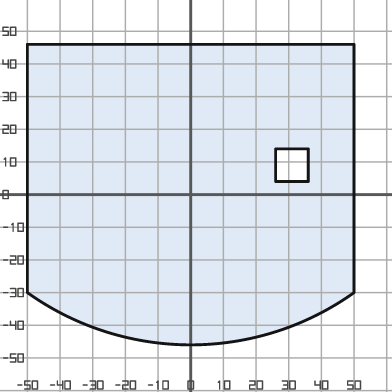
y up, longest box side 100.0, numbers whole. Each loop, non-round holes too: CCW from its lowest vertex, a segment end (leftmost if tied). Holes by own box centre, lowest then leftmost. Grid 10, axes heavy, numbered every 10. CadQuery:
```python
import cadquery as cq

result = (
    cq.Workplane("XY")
    .moveTo(-50.0, -30.0)
    .threePointArc((0.0, -46.0), (50.0, -30.0))
    .lineTo(50.0, 46.0)
    .lineTo(-50.0, 46.0)
    .close()
    .moveTo(26.0, 4.0)
    .lineTo(36.0, 4.0)
    .lineTo(36.0, 14.0)
    .lineTo(26.0, 14.0)
    .close()
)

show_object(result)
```